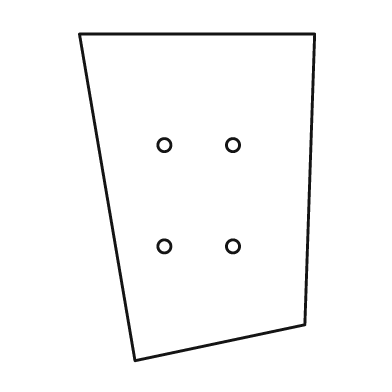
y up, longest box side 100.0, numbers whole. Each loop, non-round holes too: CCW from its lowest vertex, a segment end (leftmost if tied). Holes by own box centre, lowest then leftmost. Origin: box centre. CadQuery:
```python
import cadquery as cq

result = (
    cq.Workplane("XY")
    .moveTo(-19.0, -50.0)
    .lineTo(33.0, -39.0)
    .lineTo(36.0, 50.0)
    .lineTo(-36.0, 50.0)
    .close()
    .moveTo(-10.0, -15.0)
    .circle(2.0)
    .moveTo(11.0, -15.0)
    .circle(2.0)
    .moveTo(-10.0, 16.0)
    .circle(2.0)
    .moveTo(11.0, 16.0)
    .circle(2.0)
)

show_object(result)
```